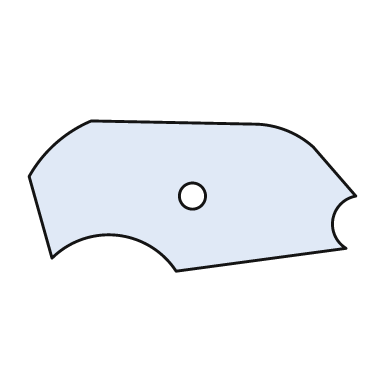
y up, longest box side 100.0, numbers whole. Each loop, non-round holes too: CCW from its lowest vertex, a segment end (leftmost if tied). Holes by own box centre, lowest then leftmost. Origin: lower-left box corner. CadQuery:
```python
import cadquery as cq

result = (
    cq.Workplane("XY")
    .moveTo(45.0, 0.0)
    .lineTo(97.0, 7.0)
    .threePointArc((93.0, 16.0), (100.0, 23.0))
    .lineTo(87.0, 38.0)
    .threePointArc((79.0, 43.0), (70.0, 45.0))
    .lineTo(19.0, 46.0)
    .threePointArc((8.0, 39.0), (0.0, 29.0))
    .lineTo(7.0, 4.0)
    .threePointArc((27.0, 11.0), (45.0, 0.0))
    .close()
    .moveTo(50.0, 23.0)
    .circle(4.0)
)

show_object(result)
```